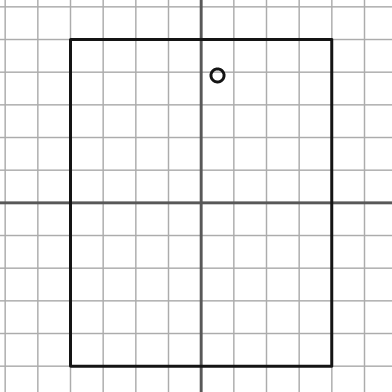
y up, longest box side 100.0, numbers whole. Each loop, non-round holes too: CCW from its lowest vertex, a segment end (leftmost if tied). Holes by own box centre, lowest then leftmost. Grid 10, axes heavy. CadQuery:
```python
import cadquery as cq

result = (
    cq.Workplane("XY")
    .moveTo(-40.0, -50.0)
    .lineTo(40.0, -50.0)
    .lineTo(40.0, 50.0)
    .lineTo(-40.0, 50.0)
    .close()
    .moveTo(5.0, 39.0)
    .circle(2.0)
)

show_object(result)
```